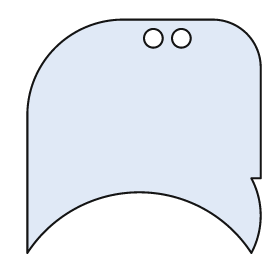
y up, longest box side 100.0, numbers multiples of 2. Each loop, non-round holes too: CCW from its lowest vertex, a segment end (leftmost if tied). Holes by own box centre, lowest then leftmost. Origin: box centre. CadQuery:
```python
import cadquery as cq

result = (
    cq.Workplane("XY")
    .moveTo(-50.0, -50.0)
    .threePointArc((-2.0, -24.0), (46.0, -50.0))
    .threePointArc((50.0, -34.0), (46.0, -18.0))
    .lineTo(50.0, -18.0)
    .lineTo(50.0, 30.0)
    .threePointArc((44.0, 44.0), (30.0, 50.0))
    .lineTo(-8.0, 50.0)
    .threePointArc((-38.0, 38.0), (-50.0, 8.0))
    .close()
    .moveTo(4.0, 42.0)
    .circle(4.0)
    .moveTo(16.0, 42.0)
    .circle(4.0)
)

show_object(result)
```